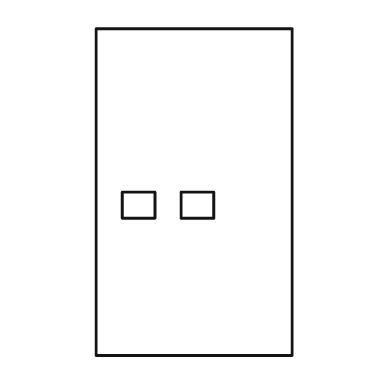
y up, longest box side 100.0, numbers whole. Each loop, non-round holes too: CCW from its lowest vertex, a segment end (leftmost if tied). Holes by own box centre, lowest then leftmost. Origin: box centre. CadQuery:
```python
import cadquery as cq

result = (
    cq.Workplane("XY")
    .moveTo(-30.0, -50.0)
    .lineTo(30.0, -50.0)
    .lineTo(30.0, 50.0)
    .lineTo(-30.0, 50.0)
    .close()
    .moveTo(-22.0, -8.0)
    .lineTo(-12.0, -8.0)
    .lineTo(-12.0, 0.0)
    .lineTo(-22.0, 0.0)
    .close()
    .moveTo(-4.0, -8.0)
    .lineTo(6.0, -8.0)
    .lineTo(6.0, 0.0)
    .lineTo(-4.0, 0.0)
    .close()
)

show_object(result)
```